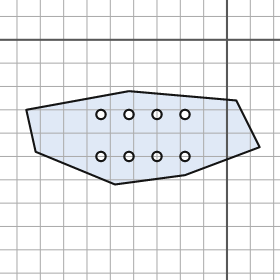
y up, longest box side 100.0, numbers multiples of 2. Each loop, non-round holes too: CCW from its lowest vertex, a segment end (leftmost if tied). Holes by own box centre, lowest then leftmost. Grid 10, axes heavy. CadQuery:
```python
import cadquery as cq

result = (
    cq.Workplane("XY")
    .moveTo(-48.0, -62.0)
    .lineTo(-18.0, -58.0)
    .lineTo(14.0, -46.0)
    .lineTo(4.0, -26.0)
    .lineTo(-42.0, -22.0)
    .lineTo(-86.0, -30.0)
    .lineTo(-82.0, -48.0)
    .close()
    .moveTo(-54.0, -50.0)
    .circle(2.0)
    .moveTo(-42.0, -50.0)
    .circle(2.0)
    .moveTo(-30.0, -50.0)
    .circle(2.0)
    .moveTo(-18.0, -50.0)
    .circle(2.0)
    .moveTo(-54.0, -32.0)
    .circle(2.0)
    .moveTo(-42.0, -32.0)
    .circle(2.0)
    .moveTo(-30.0, -32.0)
    .circle(2.0)
    .moveTo(-18.0, -32.0)
    .circle(2.0)
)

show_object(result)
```